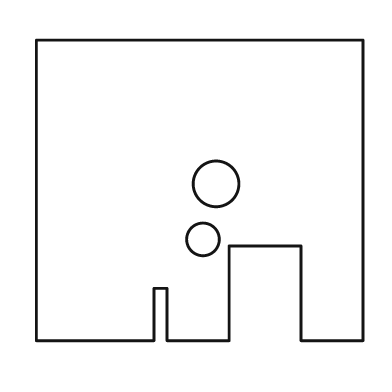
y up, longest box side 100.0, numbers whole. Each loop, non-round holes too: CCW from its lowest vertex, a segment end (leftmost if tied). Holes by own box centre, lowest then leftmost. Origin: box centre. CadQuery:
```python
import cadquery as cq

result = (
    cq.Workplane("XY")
    .moveTo(-50.0, -46.0)
    .lineTo(-14.0, -46.0)
    .lineTo(-14.0, -30.0)
    .lineTo(-10.0, -30.0)
    .lineTo(-10.0, -46.0)
    .lineTo(9.0, -46.0)
    .lineTo(9.0, -17.0)
    .lineTo(31.0, -17.0)
    .lineTo(31.0, -46.0)
    .lineTo(50.0, -46.0)
    .lineTo(50.0, 46.0)
    .lineTo(-50.0, 46.0)
    .close()
    .moveTo(1.0, -15.0)
    .circle(5.0)
    .moveTo(5.0, 2.0)
    .circle(7.0)
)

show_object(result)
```